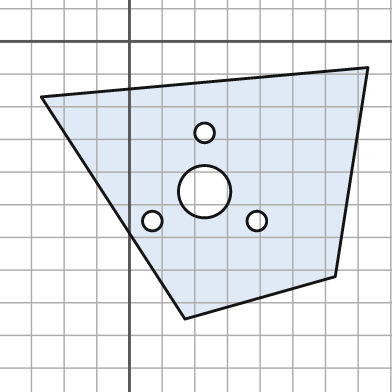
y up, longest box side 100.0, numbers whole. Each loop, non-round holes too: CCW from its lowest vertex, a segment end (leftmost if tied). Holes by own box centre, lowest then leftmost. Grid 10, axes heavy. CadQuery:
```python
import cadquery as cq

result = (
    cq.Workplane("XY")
    .moveTo(17.0, -85.0)
    .lineTo(63.0, -72.0)
    .lineTo(73.0, -8.0)
    .lineTo(-27.0, -17.0)
    .close()
    .moveTo(7.0, -55.0)
    .circle(3.0)
    .moveTo(39.0, -55.0)
    .circle(3.0)
    .moveTo(23.0, -46.0)
    .circle(8.0)
    .moveTo(23.0, -28.0)
    .circle(3.0)
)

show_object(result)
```